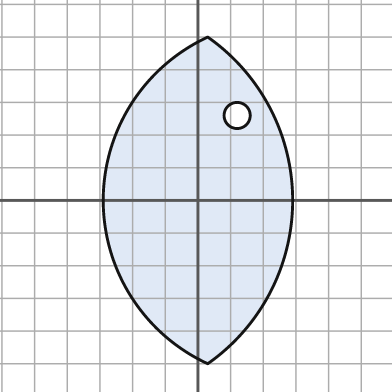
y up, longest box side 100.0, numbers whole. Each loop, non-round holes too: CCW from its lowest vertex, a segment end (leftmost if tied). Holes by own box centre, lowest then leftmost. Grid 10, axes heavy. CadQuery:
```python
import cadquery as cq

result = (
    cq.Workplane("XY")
    .moveTo(3.0, -50.0)
    .threePointArc((29.0, 0.0), (3.0, 50.0))
    .threePointArc((-29.0, 0.0), (3.0, -50.0))
    .close()
    .moveTo(12.0, 26.0)
    .circle(4.0)
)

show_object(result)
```